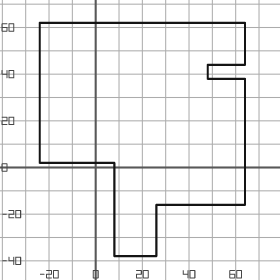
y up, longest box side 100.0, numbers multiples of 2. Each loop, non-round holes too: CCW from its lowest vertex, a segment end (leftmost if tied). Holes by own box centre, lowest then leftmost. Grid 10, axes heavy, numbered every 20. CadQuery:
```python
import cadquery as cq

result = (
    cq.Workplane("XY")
    .moveTo(8.0, -38.0)
    .lineTo(26.0, -38.0)
    .lineTo(26.0, -16.0)
    .lineTo(64.0, -16.0)
    .lineTo(64.0, 38.0)
    .lineTo(48.0, 38.0)
    .lineTo(48.0, 44.0)
    .lineTo(64.0, 44.0)
    .lineTo(64.0, 62.0)
    .lineTo(-24.0, 62.0)
    .lineTo(-24.0, 2.0)
    .lineTo(8.0, 2.0)
    .close()
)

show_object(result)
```